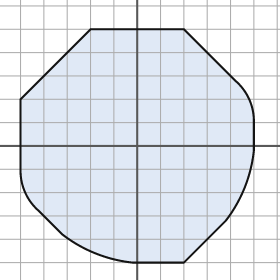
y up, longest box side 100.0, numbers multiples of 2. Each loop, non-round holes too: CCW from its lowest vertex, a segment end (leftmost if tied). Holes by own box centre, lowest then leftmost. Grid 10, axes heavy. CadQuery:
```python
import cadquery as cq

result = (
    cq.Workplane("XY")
    .moveTo(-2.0, -50.0)
    .lineTo(20.0, -50.0)
    .lineTo(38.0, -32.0)
    .threePointArc((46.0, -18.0), (50.0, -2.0))
    .lineTo(50.0, 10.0)
    .threePointArc((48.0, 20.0), (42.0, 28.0))
    .lineTo(20.0, 50.0)
    .lineTo(-20.0, 50.0)
    .lineTo(-50.0, 20.0)
    .lineTo(-50.0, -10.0)
    .threePointArc((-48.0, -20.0), (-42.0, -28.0))
    .lineTo(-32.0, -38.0)
    .threePointArc((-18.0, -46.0), (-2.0, -50.0))
    .close()
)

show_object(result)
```